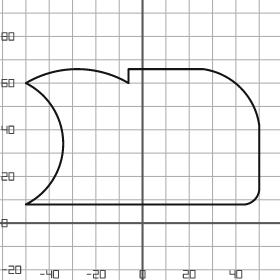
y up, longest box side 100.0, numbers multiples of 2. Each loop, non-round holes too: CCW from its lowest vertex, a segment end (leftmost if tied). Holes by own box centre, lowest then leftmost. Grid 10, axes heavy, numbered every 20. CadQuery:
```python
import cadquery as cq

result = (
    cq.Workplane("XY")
    .moveTo(-50.0, 8.0)
    .lineTo(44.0, 8.0)
    .threePointArc((48.0, 10.0), (50.0, 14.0))
    .lineTo(50.0, 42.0)
    .threePointArc((42.0, 58.0), (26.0, 66.0))
    .lineTo(-6.0, 66.0)
    .lineTo(-6.0, 60.0)
    .threePointArc((-28.0, 66.0), (-50.0, 60.0))
    .threePointArc((-34.0, 34.0), (-50.0, 8.0))
    .close()
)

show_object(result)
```